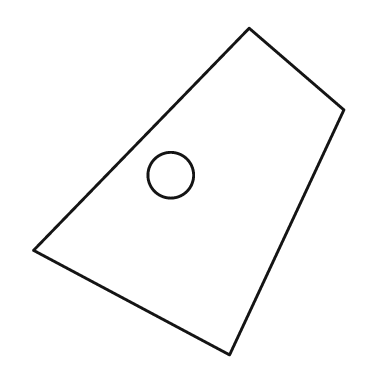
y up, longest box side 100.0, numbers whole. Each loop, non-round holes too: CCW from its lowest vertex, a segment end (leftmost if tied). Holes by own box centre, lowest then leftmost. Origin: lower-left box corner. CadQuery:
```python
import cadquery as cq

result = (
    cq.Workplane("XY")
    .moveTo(60.0, 0.0)
    .lineTo(95.0, 75.0)
    .lineTo(66.0, 100.0)
    .lineTo(0.0, 32.0)
    .close()
    .moveTo(42.0, 55.0)
    .circle(7.0)
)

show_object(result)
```